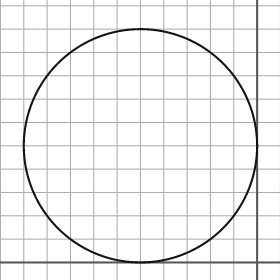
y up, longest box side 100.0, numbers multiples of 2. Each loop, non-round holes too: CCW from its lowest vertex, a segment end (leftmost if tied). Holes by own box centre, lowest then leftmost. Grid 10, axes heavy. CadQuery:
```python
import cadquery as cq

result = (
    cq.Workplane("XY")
    .moveTo(-50.0, 50.0)
    .circle(50.0)
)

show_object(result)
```